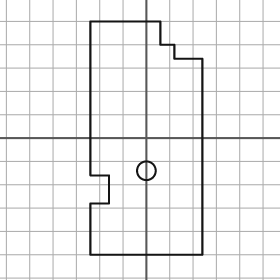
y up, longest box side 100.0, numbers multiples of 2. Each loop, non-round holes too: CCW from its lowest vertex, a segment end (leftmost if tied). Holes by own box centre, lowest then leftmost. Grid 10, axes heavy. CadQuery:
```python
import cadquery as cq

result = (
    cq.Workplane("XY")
    .moveTo(-24.0, -50.0)
    .lineTo(24.0, -50.0)
    .lineTo(24.0, 34.0)
    .lineTo(12.0, 34.0)
    .lineTo(12.0, 40.0)
    .lineTo(6.0, 40.0)
    .lineTo(6.0, 50.0)
    .lineTo(-24.0, 50.0)
    .lineTo(-24.0, -16.0)
    .lineTo(-16.0, -16.0)
    .lineTo(-16.0, -28.0)
    .lineTo(-24.0, -28.0)
    .close()
    .moveTo(0.0, -14.0)
    .circle(4.0)
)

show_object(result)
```